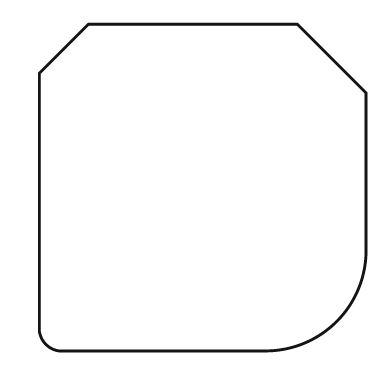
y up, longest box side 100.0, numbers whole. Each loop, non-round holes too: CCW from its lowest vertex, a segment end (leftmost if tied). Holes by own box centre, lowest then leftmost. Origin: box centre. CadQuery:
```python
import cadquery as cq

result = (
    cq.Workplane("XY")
    .moveTo(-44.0, -50.0)
    .lineTo(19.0, -50.0)
    .threePointArc((41.0, -41.0), (50.0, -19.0))
    .lineTo(50.0, 29.0)
    .lineTo(29.0, 50.0)
    .lineTo(-35.0, 50.0)
    .lineTo(-50.0, 35.0)
    .lineTo(-50.0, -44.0)
    .threePointArc((-48.0, -48.0), (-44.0, -50.0))
    .close()
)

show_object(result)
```